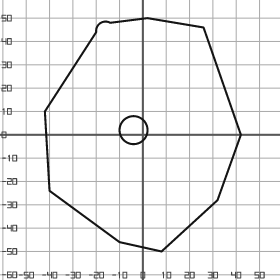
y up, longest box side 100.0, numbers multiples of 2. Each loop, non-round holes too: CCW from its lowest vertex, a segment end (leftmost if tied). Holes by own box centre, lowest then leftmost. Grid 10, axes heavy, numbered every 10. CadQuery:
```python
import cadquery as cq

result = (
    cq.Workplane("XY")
    .moveTo(8.0, -50.0)
    .lineTo(32.0, -28.0)
    .lineTo(42.0, 0.0)
    .lineTo(26.0, 46.0)
    .lineTo(2.0, 50.0)
    .lineTo(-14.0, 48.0)
    .threePointArc((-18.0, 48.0), (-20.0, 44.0))
    .lineTo(-42.0, 10.0)
    .lineTo(-40.0, -24.0)
    .lineTo(-10.0, -46.0)
    .close()
    .moveTo(-4.0, 2.0)
    .circle(6.0)
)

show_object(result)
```